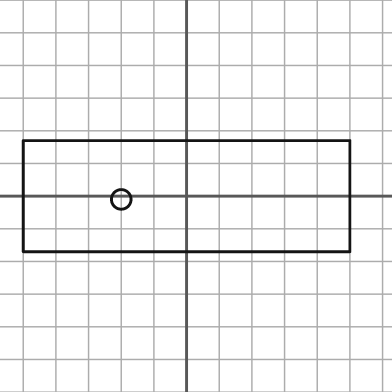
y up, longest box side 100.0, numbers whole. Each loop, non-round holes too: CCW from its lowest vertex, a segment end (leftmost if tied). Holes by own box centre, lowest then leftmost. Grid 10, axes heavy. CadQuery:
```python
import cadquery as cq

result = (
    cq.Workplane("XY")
    .moveTo(-50.0, -17.0)
    .lineTo(50.0, -17.0)
    .lineTo(50.0, 17.0)
    .lineTo(-50.0, 17.0)
    .close()
    .moveTo(-20.0, -1.0)
    .circle(3.0)
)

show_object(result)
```